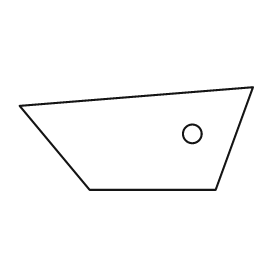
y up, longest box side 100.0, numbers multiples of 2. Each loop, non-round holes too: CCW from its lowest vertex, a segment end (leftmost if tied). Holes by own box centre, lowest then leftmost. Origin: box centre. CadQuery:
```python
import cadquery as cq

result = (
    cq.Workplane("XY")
    .moveTo(-20.0, -22.0)
    .lineTo(34.0, -22.0)
    .lineTo(50.0, 22.0)
    .lineTo(-50.0, 14.0)
    .close()
    .moveTo(24.0, 2.0)
    .circle(4.0)
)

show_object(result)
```